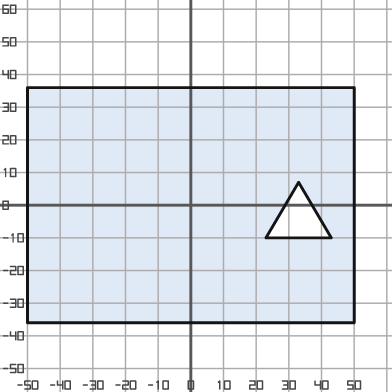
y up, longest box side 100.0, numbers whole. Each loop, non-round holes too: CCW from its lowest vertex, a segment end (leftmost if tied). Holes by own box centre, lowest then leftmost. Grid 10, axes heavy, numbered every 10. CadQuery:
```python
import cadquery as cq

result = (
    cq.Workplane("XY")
    .moveTo(-50.0, -36.0)
    .lineTo(50.0, -36.0)
    .lineTo(50.0, 36.0)
    .lineTo(-50.0, 36.0)
    .close()
    .moveTo(23.0, -10.0)
    .lineTo(43.0, -10.0)
    .lineTo(33.0, 7.0)
    .close()
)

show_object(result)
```